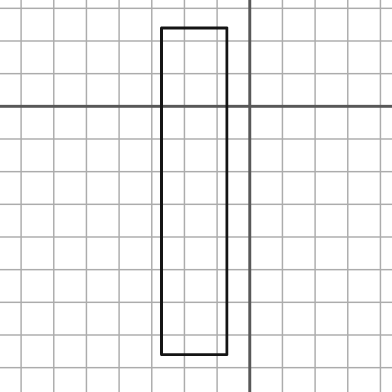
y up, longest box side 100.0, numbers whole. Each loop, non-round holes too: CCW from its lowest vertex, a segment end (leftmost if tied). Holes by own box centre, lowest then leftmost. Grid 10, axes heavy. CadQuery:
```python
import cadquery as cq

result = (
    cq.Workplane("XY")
    .moveTo(-27.0, -76.0)
    .lineTo(-7.0, -76.0)
    .lineTo(-7.0, 24.0)
    .lineTo(-27.0, 24.0)
    .close()
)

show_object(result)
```